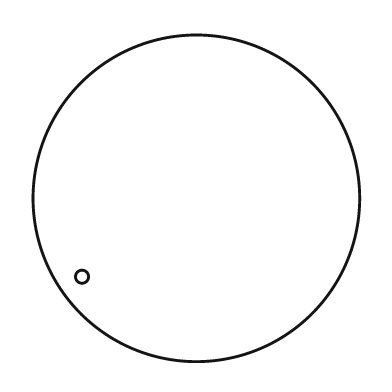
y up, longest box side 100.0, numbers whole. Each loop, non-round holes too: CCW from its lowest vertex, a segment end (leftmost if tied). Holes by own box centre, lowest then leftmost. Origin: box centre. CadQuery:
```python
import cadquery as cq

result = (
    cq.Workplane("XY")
    .moveTo(0.0, 0.0)
    .circle(50.0)
    .moveTo(-35.0, -24.0)
    .circle(2.0)
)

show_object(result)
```